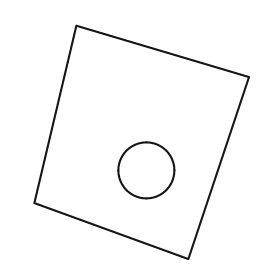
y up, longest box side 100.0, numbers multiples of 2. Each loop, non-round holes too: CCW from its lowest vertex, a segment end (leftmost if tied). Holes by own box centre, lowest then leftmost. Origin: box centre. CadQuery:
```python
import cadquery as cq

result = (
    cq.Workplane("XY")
    .moveTo(20.0, -50.0)
    .lineTo(46.0, 28.0)
    .lineTo(-28.0, 50.0)
    .lineTo(-46.0, -26.0)
    .close()
    .moveTo(2.0, -12.0)
    .circle(12.0)
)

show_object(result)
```